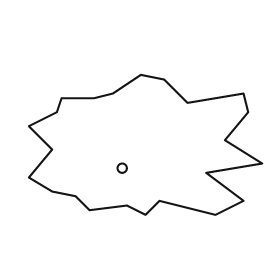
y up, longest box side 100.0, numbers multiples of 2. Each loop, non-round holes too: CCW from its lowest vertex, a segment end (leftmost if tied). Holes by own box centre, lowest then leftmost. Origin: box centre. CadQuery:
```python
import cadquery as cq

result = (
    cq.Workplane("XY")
    .moveTo(0.0, -30.0)
    .lineTo(6.0, -24.0)
    .lineTo(30.0, -30.0)
    .lineTo(42.0, -24.0)
    .lineTo(26.0, -12.0)
    .lineTo(50.0, -8.0)
    .lineTo(34.0, 2.0)
    .lineTo(44.0, 14.0)
    .lineTo(42.0, 22.0)
    .lineTo(18.0, 18.0)
    .lineTo(8.0, 28.0)
    .lineTo(-2.0, 30.0)
    .lineTo(-14.0, 22.0)
    .lineTo(-22.0, 20.0)
    .lineTo(-36.0, 20.0)
    .lineTo(-38.0, 14.0)
    .lineTo(-50.0, 8.0)
    .lineTo(-40.0, -2.0)
    .lineTo(-50.0, -14.0)
    .lineTo(-40.0, -20.0)
    .lineTo(-30.0, -22.0)
    .lineTo(-24.0, -28.0)
    .lineTo(-8.0, -26.0)
    .close()
    .moveTo(-10.0, -10.0)
    .circle(2.0)
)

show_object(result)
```